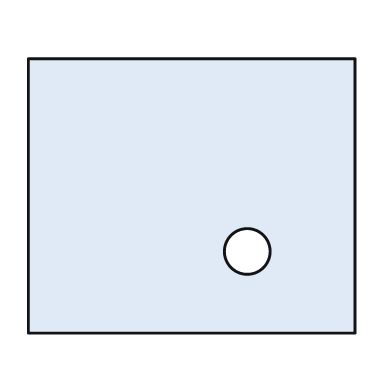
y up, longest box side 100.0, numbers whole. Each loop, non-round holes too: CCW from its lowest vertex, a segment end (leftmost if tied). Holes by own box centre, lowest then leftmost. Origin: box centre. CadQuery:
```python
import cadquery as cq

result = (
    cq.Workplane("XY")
    .moveTo(-50.0, -42.0)
    .lineTo(50.0, -42.0)
    .lineTo(50.0, 42.0)
    .lineTo(-50.0, 42.0)
    .close()
    .moveTo(17.0, -17.0)
    .circle(7.0)
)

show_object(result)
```